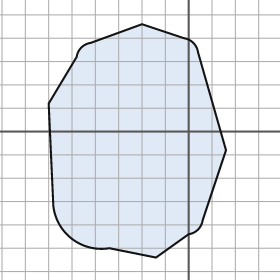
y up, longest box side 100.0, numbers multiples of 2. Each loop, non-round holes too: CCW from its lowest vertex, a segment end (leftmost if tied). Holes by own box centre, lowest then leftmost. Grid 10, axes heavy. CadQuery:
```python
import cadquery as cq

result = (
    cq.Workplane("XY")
    .moveTo(-14.0, -54.0)
    .lineTo(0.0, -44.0)
    .threePointArc((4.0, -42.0), (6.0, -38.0))
    .lineTo(16.0, -8.0)
    .lineTo(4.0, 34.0)
    .threePointArc((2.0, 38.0), (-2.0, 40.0))
    .lineTo(-20.0, 46.0)
    .lineTo(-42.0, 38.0)
    .threePointArc((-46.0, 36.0), (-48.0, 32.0))
    .lineTo(-60.0, 12.0)
    .lineTo(-58.0, -32.0)
    .threePointArc((-50.0, -46.0), (-34.0, -50.0))
    .close()
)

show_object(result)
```